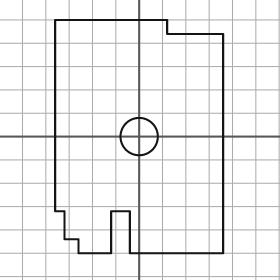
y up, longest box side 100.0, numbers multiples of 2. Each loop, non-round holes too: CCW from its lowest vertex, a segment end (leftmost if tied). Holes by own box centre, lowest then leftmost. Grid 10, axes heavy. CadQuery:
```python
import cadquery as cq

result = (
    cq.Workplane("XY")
    .moveTo(-26.0, -50.0)
    .lineTo(-12.0, -50.0)
    .lineTo(-12.0, -32.0)
    .lineTo(-4.0, -32.0)
    .lineTo(-4.0, -50.0)
    .lineTo(36.0, -50.0)
    .lineTo(36.0, 44.0)
    .lineTo(12.0, 44.0)
    .lineTo(12.0, 50.0)
    .lineTo(-36.0, 50.0)
    .lineTo(-36.0, -32.0)
    .lineTo(-32.0, -32.0)
    .lineTo(-32.0, -44.0)
    .lineTo(-26.0, -44.0)
    .close()
    .moveTo(0.0, 0.0)
    .circle(8.0)
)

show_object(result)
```